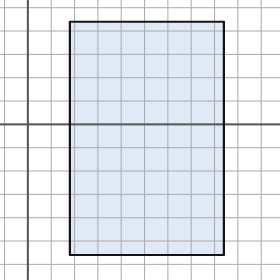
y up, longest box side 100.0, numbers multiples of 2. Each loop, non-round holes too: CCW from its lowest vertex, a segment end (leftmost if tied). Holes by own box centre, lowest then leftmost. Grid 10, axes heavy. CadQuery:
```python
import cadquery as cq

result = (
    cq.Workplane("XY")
    .moveTo(18.0, -56.0)
    .lineTo(84.0, -56.0)
    .lineTo(84.0, 44.0)
    .lineTo(18.0, 44.0)
    .close()
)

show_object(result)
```